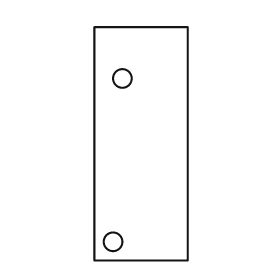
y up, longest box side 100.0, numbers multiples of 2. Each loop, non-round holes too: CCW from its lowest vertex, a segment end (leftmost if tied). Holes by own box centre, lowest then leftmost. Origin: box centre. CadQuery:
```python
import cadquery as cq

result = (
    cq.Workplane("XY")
    .moveTo(-20.0, -50.0)
    .lineTo(20.0, -50.0)
    .lineTo(20.0, 50.0)
    .lineTo(-20.0, 50.0)
    .close()
    .moveTo(-12.0, -42.0)
    .circle(4.0)
    .moveTo(-8.0, 28.0)
    .circle(4.0)
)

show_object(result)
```